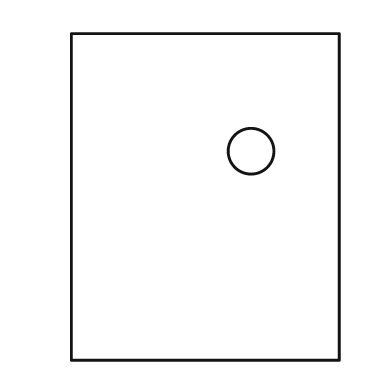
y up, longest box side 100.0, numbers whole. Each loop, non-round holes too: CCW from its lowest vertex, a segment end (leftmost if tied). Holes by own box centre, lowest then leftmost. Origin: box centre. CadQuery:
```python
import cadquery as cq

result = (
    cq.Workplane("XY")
    .moveTo(-41.0, -50.0)
    .lineTo(41.0, -50.0)
    .lineTo(41.0, 50.0)
    .lineTo(-41.0, 50.0)
    .close()
    .moveTo(14.0, 14.0)
    .circle(7.0)
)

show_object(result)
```